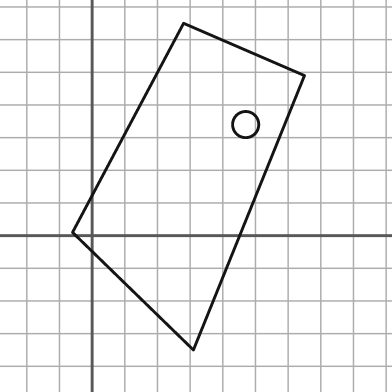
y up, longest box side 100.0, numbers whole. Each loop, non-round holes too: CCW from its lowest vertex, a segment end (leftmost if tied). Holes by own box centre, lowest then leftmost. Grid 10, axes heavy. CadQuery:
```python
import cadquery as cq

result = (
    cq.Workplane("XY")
    .moveTo(31.0, -35.0)
    .lineTo(65.0, 49.0)
    .lineTo(28.0, 65.0)
    .lineTo(-6.0, 1.0)
    .close()
    .moveTo(47.0, 34.0)
    .circle(4.0)
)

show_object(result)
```